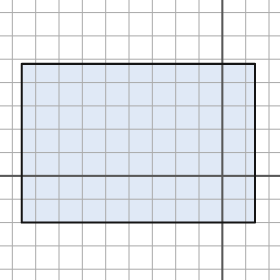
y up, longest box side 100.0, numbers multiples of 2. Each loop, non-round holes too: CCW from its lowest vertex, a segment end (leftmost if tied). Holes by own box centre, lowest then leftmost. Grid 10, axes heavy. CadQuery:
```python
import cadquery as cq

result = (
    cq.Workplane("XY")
    .moveTo(-86.0, -20.0)
    .lineTo(14.0, -20.0)
    .lineTo(14.0, 48.0)
    .lineTo(-86.0, 48.0)
    .close()
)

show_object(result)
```